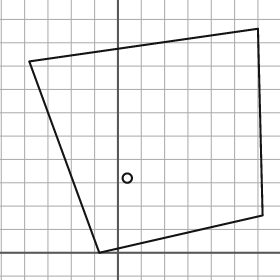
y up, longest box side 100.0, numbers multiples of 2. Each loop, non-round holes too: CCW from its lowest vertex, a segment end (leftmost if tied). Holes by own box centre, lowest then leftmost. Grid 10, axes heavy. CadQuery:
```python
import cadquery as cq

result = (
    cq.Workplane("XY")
    .moveTo(-8.0, 0.0)
    .lineTo(62.0, 16.0)
    .lineTo(60.0, 96.0)
    .lineTo(-38.0, 82.0)
    .close()
    .moveTo(4.0, 32.0)
    .circle(2.0)
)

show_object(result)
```